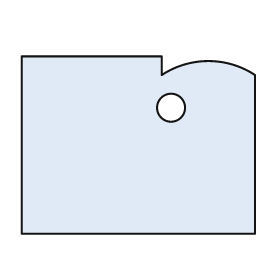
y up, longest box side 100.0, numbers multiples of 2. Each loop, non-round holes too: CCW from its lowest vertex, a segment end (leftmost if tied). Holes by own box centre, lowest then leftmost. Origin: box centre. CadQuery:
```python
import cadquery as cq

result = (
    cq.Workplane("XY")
    .moveTo(-50.0, -38.0)
    .lineTo(50.0, -38.0)
    .lineTo(50.0, 30.0)
    .threePointArc((30.0, 36.0), (10.0, 30.0))
    .lineTo(10.0, 38.0)
    .lineTo(-50.0, 38.0)
    .close()
    .moveTo(14.0, 16.0)
    .circle(6.0)
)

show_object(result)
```